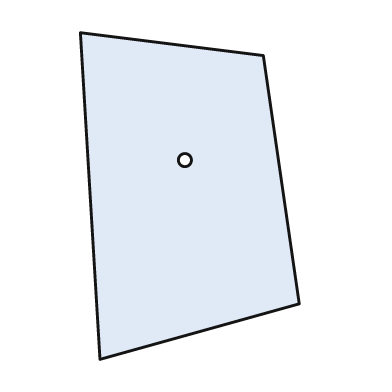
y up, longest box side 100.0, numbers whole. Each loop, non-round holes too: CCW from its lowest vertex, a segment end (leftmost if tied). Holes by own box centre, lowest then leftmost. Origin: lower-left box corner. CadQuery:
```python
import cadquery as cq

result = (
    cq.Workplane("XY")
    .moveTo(6.0, 0.0)
    .lineTo(67.0, 17.0)
    .lineTo(56.0, 93.0)
    .lineTo(0.0, 100.0)
    .close()
    .moveTo(32.0, 61.0)
    .circle(2.0)
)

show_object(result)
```